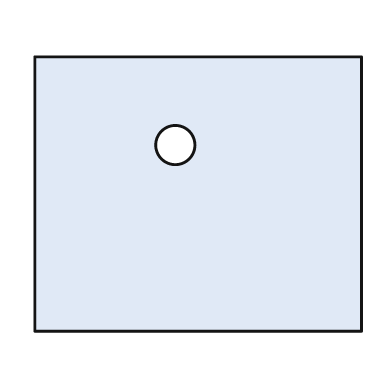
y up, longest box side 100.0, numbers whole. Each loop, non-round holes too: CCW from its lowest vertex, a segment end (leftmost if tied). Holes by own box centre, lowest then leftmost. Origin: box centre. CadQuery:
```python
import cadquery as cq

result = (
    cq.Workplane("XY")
    .moveTo(-50.0, -42.0)
    .lineTo(50.0, -42.0)
    .lineTo(50.0, 42.0)
    .lineTo(-50.0, 42.0)
    .close()
    .moveTo(-7.0, 15.0)
    .circle(6.0)
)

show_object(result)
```